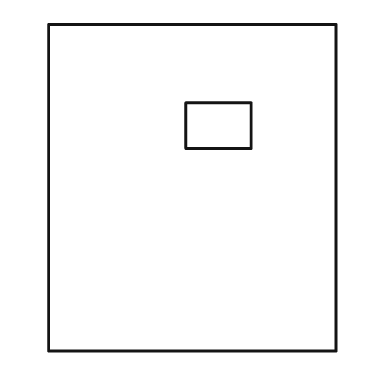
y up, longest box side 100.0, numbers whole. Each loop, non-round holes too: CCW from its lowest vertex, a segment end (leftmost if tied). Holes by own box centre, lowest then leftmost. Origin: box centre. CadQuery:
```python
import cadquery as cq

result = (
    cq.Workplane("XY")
    .moveTo(-44.0, -50.0)
    .lineTo(44.0, -50.0)
    .lineTo(44.0, 50.0)
    .lineTo(-44.0, 50.0)
    .close()
    .moveTo(-2.0, 12.0)
    .lineTo(18.0, 12.0)
    .lineTo(18.0, 26.0)
    .lineTo(-2.0, 26.0)
    .close()
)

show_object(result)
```